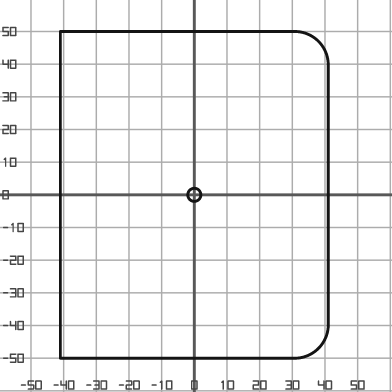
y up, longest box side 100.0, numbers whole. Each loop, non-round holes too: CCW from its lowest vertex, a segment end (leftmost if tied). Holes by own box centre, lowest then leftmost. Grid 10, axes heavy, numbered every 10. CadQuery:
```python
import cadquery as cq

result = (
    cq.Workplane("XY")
    .moveTo(-41.0, -50.0)
    .lineTo(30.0, -50.0)
    .threePointArc((38.0, -47.0), (41.0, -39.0))
    .lineTo(41.0, 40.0)
    .threePointArc((38.0, 47.0), (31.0, 50.0))
    .lineTo(-41.0, 50.0)
    .close()
    .moveTo(0.0, 0.0)
    .circle(2.0)
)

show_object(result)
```